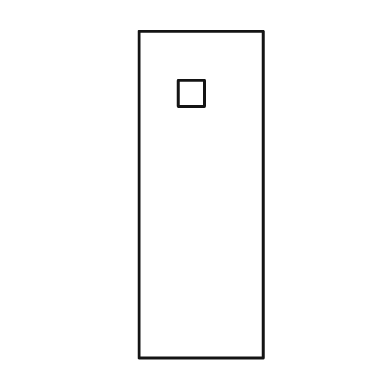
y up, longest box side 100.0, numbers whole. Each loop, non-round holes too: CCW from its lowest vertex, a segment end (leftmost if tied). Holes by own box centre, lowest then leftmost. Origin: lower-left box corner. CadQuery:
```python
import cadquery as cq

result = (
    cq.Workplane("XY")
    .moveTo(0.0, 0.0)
    .lineTo(38.0, 0.0)
    .lineTo(38.0, 100.0)
    .lineTo(0.0, 100.0)
    .close()
    .moveTo(12.0, 77.0)
    .lineTo(20.0, 77.0)
    .lineTo(20.0, 85.0)
    .lineTo(12.0, 85.0)
    .close()
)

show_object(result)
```